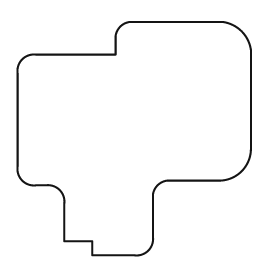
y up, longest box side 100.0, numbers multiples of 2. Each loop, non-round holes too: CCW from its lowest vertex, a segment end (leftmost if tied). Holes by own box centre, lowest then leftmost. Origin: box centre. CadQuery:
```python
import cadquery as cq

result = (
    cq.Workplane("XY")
    .moveTo(-18.0, -50.0)
    .lineTo(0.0, -50.0)
    .threePointArc((6.0, -48.0), (8.0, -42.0))
    .lineTo(8.0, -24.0)
    .threePointArc((10.0, -20.0), (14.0, -18.0))
    .lineTo(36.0, -18.0)
    .threePointArc((46.0, -14.0), (50.0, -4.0))
    .lineTo(50.0, 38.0)
    .threePointArc((46.0, 46.0), (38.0, 50.0))
    .lineTo(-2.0, 50.0)
    .threePointArc((-6.0, 48.0), (-8.0, 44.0))
    .lineTo(-8.0, 36.0)
    .lineTo(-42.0, 36.0)
    .threePointArc((-48.0, 34.0), (-50.0, 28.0))
    .lineTo(-50.0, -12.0)
    .threePointArc((-48.0, -18.0), (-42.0, -20.0))
    .lineTo(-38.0, -20.0)
    .threePointArc((-32.0, -22.0), (-30.0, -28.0))
    .lineTo(-30.0, -44.0)
    .lineTo(-18.0, -44.0)
    .close()
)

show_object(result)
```